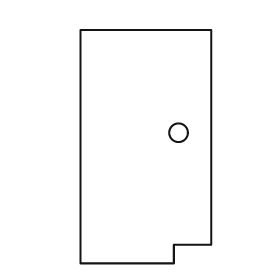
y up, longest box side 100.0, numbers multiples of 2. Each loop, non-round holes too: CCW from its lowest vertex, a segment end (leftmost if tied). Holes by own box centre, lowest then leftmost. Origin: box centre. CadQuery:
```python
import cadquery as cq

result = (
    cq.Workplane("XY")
    .moveTo(-28.0, -50.0)
    .lineTo(12.0, -50.0)
    .lineTo(12.0, -42.0)
    .lineTo(28.0, -42.0)
    .lineTo(28.0, 50.0)
    .lineTo(-28.0, 50.0)
    .close()
    .moveTo(14.0, 6.0)
    .circle(4.0)
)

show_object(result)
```